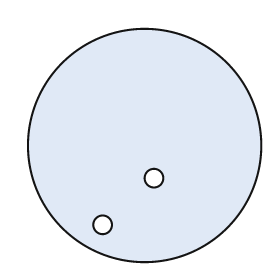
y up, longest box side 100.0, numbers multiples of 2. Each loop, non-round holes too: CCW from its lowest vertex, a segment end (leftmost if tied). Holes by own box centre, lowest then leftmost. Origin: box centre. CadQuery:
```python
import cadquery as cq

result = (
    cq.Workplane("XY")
    .moveTo(0.0, 0.0)
    .circle(50.0)
    .moveTo(-18.0, -34.0)
    .circle(4.0)
    .moveTo(4.0, -14.0)
    .circle(4.0)
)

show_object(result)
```